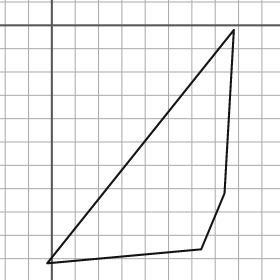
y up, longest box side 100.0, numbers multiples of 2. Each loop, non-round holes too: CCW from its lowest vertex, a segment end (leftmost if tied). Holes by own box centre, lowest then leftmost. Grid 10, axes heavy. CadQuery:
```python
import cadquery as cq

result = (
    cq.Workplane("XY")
    .moveTo(-2.0, -102.0)
    .lineTo(64.0, -96.0)
    .lineTo(74.0, -72.0)
    .lineTo(78.0, -2.0)
    .close()
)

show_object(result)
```